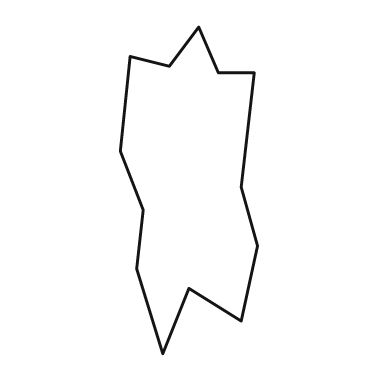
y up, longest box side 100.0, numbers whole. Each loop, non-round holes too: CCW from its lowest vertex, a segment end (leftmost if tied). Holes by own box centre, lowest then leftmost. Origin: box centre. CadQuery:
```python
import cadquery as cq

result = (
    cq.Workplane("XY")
    .moveTo(-8.0, -50.0)
    .lineTo(0.0, -30.0)
    .lineTo(16.0, -40.0)
    .lineTo(21.0, -17.0)
    .lineTo(16.0, 1.0)
    .lineTo(20.0, 36.0)
    .lineTo(9.0, 36.0)
    .lineTo(3.0, 50.0)
    .lineTo(-6.0, 38.0)
    .lineTo(-18.0, 41.0)
    .lineTo(-21.0, 12.0)
    .lineTo(-14.0, -6.0)
    .lineTo(-16.0, -24.0)
    .close()
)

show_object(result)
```